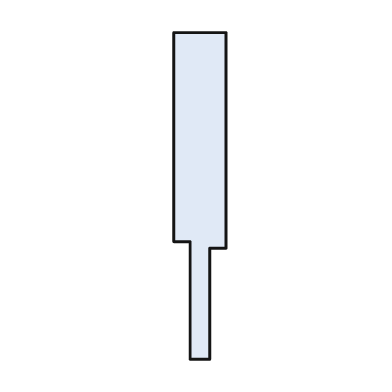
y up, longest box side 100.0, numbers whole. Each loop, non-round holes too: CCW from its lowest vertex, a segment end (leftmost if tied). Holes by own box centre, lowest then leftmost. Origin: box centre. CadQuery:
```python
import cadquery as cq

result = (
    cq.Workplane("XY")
    .moveTo(-3.0, -50.0)
    .lineTo(3.0, -50.0)
    .lineTo(3.0, -16.0)
    .lineTo(8.0, -16.0)
    .lineTo(8.0, 50.0)
    .lineTo(-8.0, 50.0)
    .lineTo(-8.0, -14.0)
    .lineTo(-3.0, -14.0)
    .close()
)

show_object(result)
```